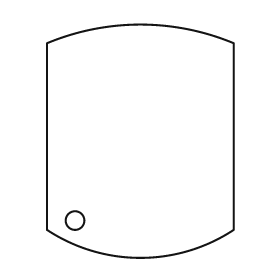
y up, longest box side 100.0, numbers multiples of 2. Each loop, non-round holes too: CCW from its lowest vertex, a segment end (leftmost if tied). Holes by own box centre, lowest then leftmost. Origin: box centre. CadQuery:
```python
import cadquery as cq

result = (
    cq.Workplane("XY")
    .moveTo(-40.0, -38.0)
    .threePointArc((0.0, -50.0), (40.0, -38.0))
    .lineTo(40.0, 42.0)
    .threePointArc((0.0, 50.0), (-40.0, 42.0))
    .close()
    .moveTo(-28.0, -34.0)
    .circle(4.0)
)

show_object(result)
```